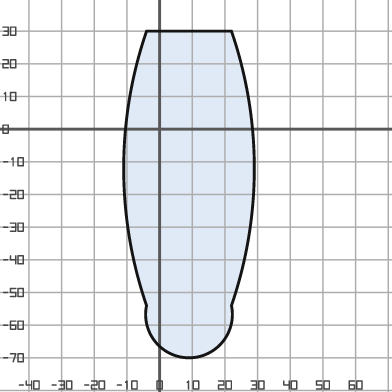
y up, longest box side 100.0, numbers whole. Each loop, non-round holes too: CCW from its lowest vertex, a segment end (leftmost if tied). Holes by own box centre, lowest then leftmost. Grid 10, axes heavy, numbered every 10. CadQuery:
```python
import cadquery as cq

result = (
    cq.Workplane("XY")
    .moveTo(-4.0, -54.0)
    .threePointArc((9.0, -70.0), (22.0, -54.0))
    .threePointArc((29.0, -12.0), (22.0, 30.0))
    .lineTo(-4.0, 30.0)
    .threePointArc((-11.0, -12.0), (-4.0, -54.0))
    .close()
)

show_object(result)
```